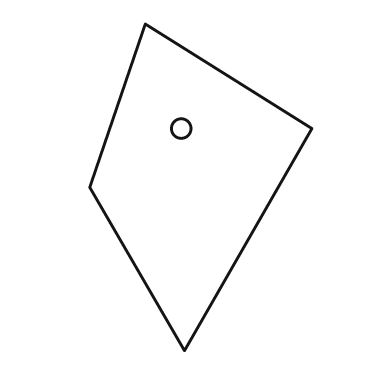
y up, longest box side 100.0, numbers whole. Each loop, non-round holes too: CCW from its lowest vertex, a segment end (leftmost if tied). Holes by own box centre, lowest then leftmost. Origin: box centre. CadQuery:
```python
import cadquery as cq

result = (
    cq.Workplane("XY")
    .moveTo(-5.0, -50.0)
    .lineTo(34.0, 18.0)
    .lineTo(-17.0, 50.0)
    .lineTo(-34.0, 0.0)
    .close()
    .moveTo(-6.0, 18.0)
    .circle(3.0)
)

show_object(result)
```